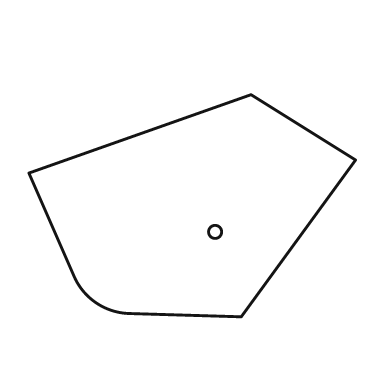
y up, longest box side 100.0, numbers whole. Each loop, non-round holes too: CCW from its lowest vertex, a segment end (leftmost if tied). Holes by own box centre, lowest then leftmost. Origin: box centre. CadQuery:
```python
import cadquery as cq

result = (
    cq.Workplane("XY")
    .moveTo(15.0, -34.0)
    .lineTo(50.0, 14.0)
    .lineTo(18.0, 34.0)
    .lineTo(-50.0, 10.0)
    .lineTo(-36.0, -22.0)
    .threePointArc((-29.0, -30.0), (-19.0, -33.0))
    .close()
    .moveTo(7.0, -8.0)
    .circle(2.0)
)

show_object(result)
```